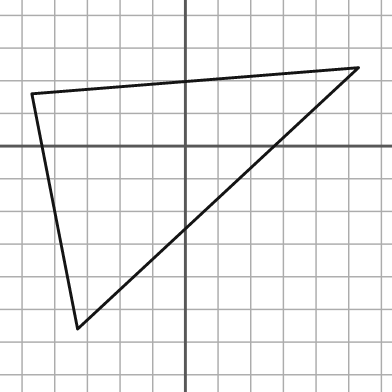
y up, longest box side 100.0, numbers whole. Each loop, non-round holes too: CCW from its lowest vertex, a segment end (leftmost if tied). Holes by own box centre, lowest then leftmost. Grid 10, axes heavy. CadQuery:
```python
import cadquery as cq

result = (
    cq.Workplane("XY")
    .moveTo(-33.0, -56.0)
    .lineTo(53.0, 24.0)
    .lineTo(-47.0, 16.0)
    .close()
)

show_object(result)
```